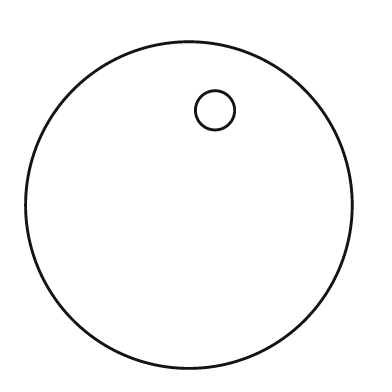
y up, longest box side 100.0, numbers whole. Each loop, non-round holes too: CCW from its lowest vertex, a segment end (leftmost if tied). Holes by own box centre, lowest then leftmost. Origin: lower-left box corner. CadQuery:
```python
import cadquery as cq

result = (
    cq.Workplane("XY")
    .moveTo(50.0, 50.0)
    .circle(50.0)
    .moveTo(58.0, 79.0)
    .circle(6.0)
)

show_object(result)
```